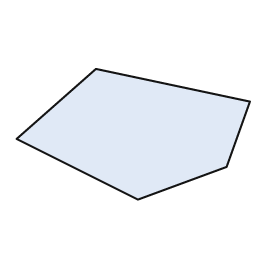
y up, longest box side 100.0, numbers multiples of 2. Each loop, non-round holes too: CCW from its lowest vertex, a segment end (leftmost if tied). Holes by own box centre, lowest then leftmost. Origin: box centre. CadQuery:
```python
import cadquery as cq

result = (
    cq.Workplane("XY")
    .moveTo(2.0, -28.0)
    .lineTo(40.0, -14.0)
    .lineTo(50.0, 14.0)
    .lineTo(-16.0, 28.0)
    .lineTo(-50.0, -2.0)
    .close()
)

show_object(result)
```